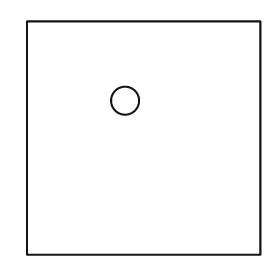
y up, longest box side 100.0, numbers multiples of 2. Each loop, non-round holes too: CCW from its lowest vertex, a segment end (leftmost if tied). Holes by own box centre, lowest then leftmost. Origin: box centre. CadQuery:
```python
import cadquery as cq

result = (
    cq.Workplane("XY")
    .moveTo(-50.0, -50.0)
    .lineTo(50.0, -50.0)
    .lineTo(50.0, 50.0)
    .lineTo(-50.0, 50.0)
    .close()
    .moveTo(-8.0, 16.0)
    .circle(6.0)
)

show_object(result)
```